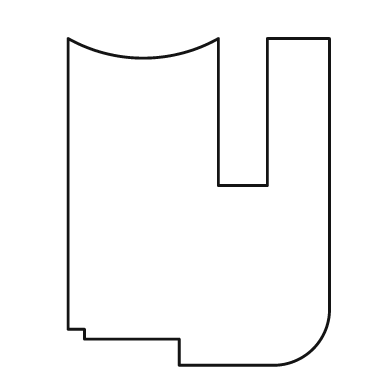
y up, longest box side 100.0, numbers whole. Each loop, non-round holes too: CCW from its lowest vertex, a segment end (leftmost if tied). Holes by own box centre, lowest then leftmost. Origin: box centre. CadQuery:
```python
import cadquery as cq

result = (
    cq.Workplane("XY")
    .moveTo(-6.0, -50.0)
    .lineTo(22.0, -50.0)
    .threePointArc((35.0, -45.0), (40.0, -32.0))
    .lineTo(40.0, 50.0)
    .lineTo(21.0, 50.0)
    .lineTo(21.0, 5.0)
    .lineTo(6.0, 5.0)
    .lineTo(6.0, 50.0)
    .threePointArc((-17.0, 44.0), (-40.0, 50.0))
    .lineTo(-40.0, -39.0)
    .lineTo(-35.0, -39.0)
    .lineTo(-35.0, -42.0)
    .lineTo(-6.0, -42.0)
    .close()
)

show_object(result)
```